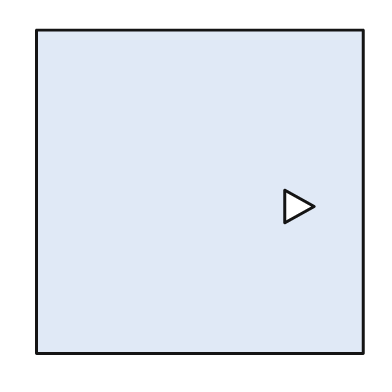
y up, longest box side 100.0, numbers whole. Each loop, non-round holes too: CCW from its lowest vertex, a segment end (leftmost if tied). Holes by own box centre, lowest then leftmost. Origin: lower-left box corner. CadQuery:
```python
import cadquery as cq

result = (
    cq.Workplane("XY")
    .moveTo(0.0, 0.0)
    .lineTo(100.0, 0.0)
    .lineTo(100.0, 99.0)
    .lineTo(0.0, 99.0)
    .close()
    .moveTo(76.0, 40.0)
    .lineTo(85.0, 45.0)
    .lineTo(76.0, 50.0)
    .close()
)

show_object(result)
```